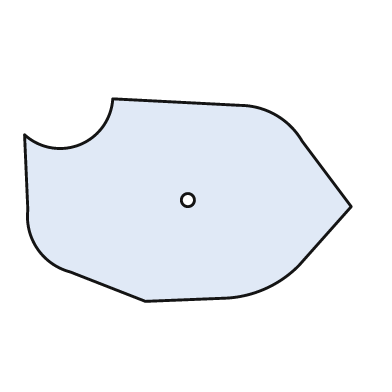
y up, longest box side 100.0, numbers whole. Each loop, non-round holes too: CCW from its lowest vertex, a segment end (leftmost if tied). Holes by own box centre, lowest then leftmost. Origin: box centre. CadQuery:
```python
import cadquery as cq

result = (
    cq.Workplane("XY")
    .moveTo(-13.0, -31.0)
    .lineTo(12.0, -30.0)
    .threePointArc((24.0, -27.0), (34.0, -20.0))
    .lineTo(50.0, -2.0)
    .lineTo(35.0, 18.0)
    .threePointArc((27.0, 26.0), (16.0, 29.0))
    .lineTo(-23.0, 31.0)
    .threePointArc((-33.0, 17.0), (-50.0, 20.0))
    .lineTo(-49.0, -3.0)
    .threePointArc((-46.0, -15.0), (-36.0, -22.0))
    .close()
    .moveTo(0.0, 0.0)
    .circle(2.0)
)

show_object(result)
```